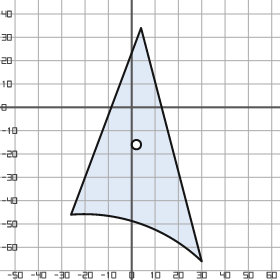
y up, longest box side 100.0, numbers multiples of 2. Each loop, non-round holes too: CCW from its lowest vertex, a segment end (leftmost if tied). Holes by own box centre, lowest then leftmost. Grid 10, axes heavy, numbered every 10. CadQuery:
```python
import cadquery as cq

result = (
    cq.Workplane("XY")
    .moveTo(30.0, -66.0)
    .lineTo(4.0, 34.0)
    .lineTo(-26.0, -46.0)
    .threePointArc((4.0, -50.0), (30.0, -66.0))
    .close()
    .moveTo(2.0, -16.0)
    .circle(2.0)
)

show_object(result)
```